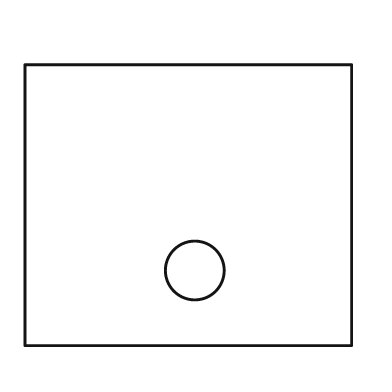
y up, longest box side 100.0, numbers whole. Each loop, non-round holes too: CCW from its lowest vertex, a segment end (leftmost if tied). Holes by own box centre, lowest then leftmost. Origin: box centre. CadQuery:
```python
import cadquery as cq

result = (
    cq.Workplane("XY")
    .moveTo(-50.0, -43.0)
    .lineTo(50.0, -43.0)
    .lineTo(50.0, 43.0)
    .lineTo(-50.0, 43.0)
    .close()
    .moveTo(2.0, -20.0)
    .circle(9.0)
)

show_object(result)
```